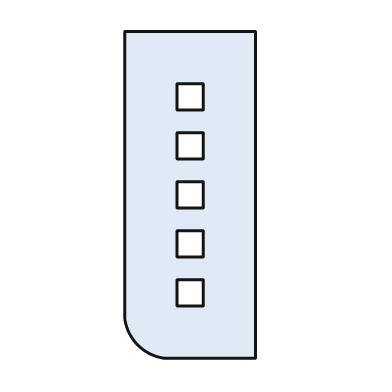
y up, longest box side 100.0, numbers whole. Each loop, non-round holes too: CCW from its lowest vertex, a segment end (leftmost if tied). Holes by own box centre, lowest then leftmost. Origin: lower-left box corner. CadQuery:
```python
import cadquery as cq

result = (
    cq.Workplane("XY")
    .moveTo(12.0, 0.0)
    .lineTo(40.0, 0.0)
    .lineTo(40.0, 100.0)
    .lineTo(0.0, 100.0)
    .lineTo(0.0, 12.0)
    .threePointArc((4.0, 4.0), (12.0, 0.0))
    .close()
    .moveTo(16.0, 16.0)
    .lineTo(24.0, 16.0)
    .lineTo(24.0, 24.0)
    .lineTo(16.0, 24.0)
    .close()
    .moveTo(16.0, 31.0)
    .lineTo(24.0, 31.0)
    .lineTo(24.0, 39.0)
    .lineTo(16.0, 39.0)
    .close()
    .moveTo(16.0, 46.0)
    .lineTo(24.0, 46.0)
    .lineTo(24.0, 54.0)
    .lineTo(16.0, 54.0)
    .close()
    .moveTo(16.0, 61.0)
    .lineTo(24.0, 61.0)
    .lineTo(24.0, 69.0)
    .lineTo(16.0, 69.0)
    .close()
    .moveTo(16.0, 76.0)
    .lineTo(24.0, 76.0)
    .lineTo(24.0, 84.0)
    .lineTo(16.0, 84.0)
    .close()
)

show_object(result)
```